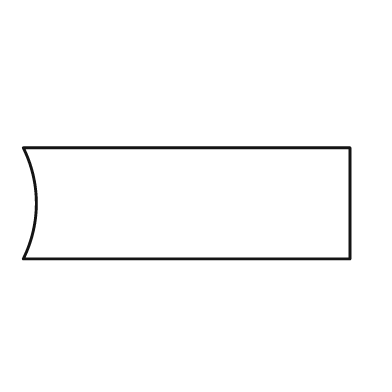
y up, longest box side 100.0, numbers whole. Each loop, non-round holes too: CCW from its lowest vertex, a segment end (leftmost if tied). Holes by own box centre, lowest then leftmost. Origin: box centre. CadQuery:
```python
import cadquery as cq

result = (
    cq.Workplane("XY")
    .moveTo(-50.0, -17.0)
    .lineTo(50.0, -17.0)
    .lineTo(50.0, 17.0)
    .lineTo(-50.0, 17.0)
    .threePointArc((-46.0, 0.0), (-50.0, -17.0))
    .close()
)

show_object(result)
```